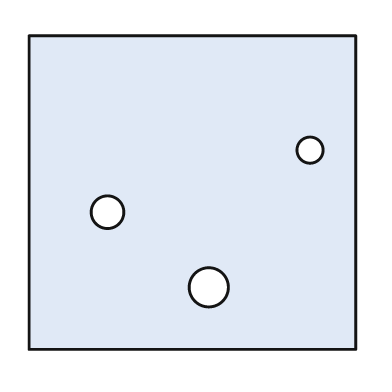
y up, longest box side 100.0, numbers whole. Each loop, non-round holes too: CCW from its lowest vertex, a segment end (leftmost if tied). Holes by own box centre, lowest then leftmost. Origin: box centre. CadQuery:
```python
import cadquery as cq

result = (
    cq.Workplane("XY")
    .moveTo(-50.0, -48.0)
    .lineTo(50.0, -48.0)
    .lineTo(50.0, 48.0)
    .lineTo(-50.0, 48.0)
    .close()
    .moveTo(5.0, -29.0)
    .circle(6.0)
    .moveTo(-26.0, -6.0)
    .circle(5.0)
    .moveTo(36.0, 13.0)
    .circle(4.0)
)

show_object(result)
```